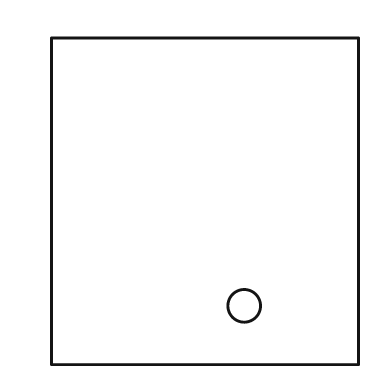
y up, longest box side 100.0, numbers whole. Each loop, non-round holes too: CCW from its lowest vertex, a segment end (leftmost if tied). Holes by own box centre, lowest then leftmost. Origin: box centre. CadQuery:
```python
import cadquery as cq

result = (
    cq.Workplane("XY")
    .moveTo(-47.0, -50.0)
    .lineTo(47.0, -50.0)
    .lineTo(47.0, 50.0)
    .lineTo(-47.0, 50.0)
    .close()
    .moveTo(12.0, -32.0)
    .circle(5.0)
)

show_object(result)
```